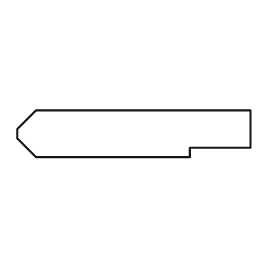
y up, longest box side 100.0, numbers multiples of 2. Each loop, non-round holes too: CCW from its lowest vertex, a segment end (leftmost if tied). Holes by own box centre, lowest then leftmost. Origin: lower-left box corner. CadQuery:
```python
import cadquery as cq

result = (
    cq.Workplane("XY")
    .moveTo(8.0, 0.0)
    .lineTo(74.0, 0.0)
    .lineTo(74.0, 4.0)
    .lineTo(100.0, 4.0)
    .lineTo(100.0, 20.0)
    .lineTo(8.0, 20.0)
    .lineTo(0.0, 12.0)
    .lineTo(0.0, 8.0)
    .close()
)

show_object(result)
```